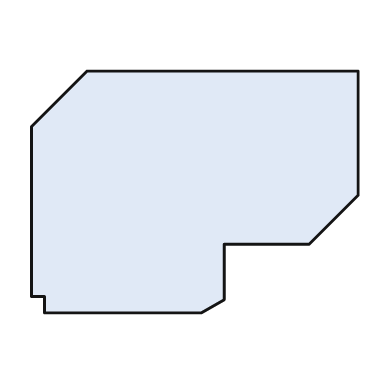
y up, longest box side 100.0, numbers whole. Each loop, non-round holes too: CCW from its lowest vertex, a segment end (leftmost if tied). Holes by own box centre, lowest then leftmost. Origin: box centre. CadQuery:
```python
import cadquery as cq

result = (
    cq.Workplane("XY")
    .moveTo(-46.0, -37.0)
    .lineTo(2.0, -37.0)
    .lineTo(9.0, -33.0)
    .lineTo(9.0, -16.0)
    .lineTo(35.0, -16.0)
    .lineTo(50.0, -1.0)
    .lineTo(50.0, 37.0)
    .lineTo(-33.0, 37.0)
    .lineTo(-50.0, 20.0)
    .lineTo(-50.0, -32.0)
    .lineTo(-46.0, -32.0)
    .close()
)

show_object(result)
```